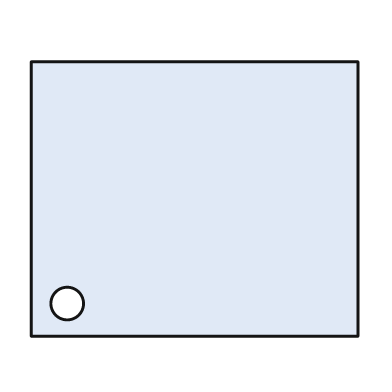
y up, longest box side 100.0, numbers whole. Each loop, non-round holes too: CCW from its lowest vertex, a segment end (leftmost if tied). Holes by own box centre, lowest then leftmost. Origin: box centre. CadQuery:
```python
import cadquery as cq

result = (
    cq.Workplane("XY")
    .moveTo(-50.0, -42.0)
    .lineTo(50.0, -42.0)
    .lineTo(50.0, 42.0)
    .lineTo(-50.0, 42.0)
    .close()
    .moveTo(-39.0, -32.0)
    .circle(5.0)
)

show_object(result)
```